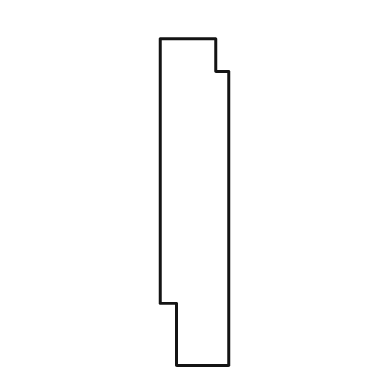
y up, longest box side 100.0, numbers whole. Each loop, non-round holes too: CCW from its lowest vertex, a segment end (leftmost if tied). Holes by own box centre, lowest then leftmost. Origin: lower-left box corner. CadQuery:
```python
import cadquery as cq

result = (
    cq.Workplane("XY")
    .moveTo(5.0, 0.0)
    .lineTo(21.0, 0.0)
    .lineTo(21.0, 90.0)
    .lineTo(17.0, 90.0)
    .lineTo(17.0, 100.0)
    .lineTo(0.0, 100.0)
    .lineTo(0.0, 19.0)
    .lineTo(5.0, 19.0)
    .close()
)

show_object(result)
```